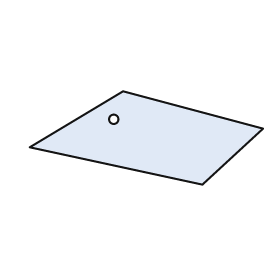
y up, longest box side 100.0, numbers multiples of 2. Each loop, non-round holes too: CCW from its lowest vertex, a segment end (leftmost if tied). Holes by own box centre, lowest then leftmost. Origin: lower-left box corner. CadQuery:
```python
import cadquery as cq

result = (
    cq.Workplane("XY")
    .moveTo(74.0, 0.0)
    .lineTo(100.0, 24.0)
    .lineTo(40.0, 40.0)
    .lineTo(0.0, 16.0)
    .close()
    .moveTo(36.0, 28.0)
    .circle(2.0)
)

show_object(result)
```